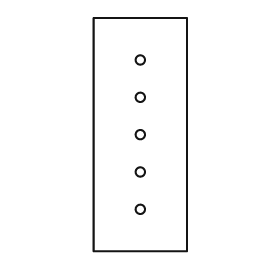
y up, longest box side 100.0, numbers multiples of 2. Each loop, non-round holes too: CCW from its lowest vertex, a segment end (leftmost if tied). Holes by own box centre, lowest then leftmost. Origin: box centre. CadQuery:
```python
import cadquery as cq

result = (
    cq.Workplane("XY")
    .moveTo(-20.0, -50.0)
    .lineTo(20.0, -50.0)
    .lineTo(20.0, 50.0)
    .lineTo(-20.0, 50.0)
    .close()
    .moveTo(0.0, -32.0)
    .circle(2.0)
    .moveTo(0.0, -16.0)
    .circle(2.0)
    .moveTo(0.0, 0.0)
    .circle(2.0)
    .moveTo(0.0, 16.0)
    .circle(2.0)
    .moveTo(0.0, 32.0)
    .circle(2.0)
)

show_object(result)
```